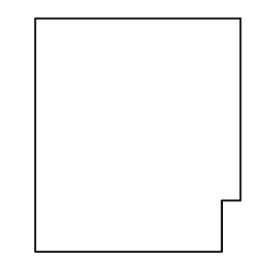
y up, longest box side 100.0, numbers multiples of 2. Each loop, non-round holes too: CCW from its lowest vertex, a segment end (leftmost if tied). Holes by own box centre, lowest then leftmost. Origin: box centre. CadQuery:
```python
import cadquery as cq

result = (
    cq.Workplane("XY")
    .moveTo(-44.0, -50.0)
    .lineTo(36.0, -50.0)
    .lineTo(36.0, -28.0)
    .lineTo(44.0, -28.0)
    .lineTo(44.0, 50.0)
    .lineTo(-44.0, 50.0)
    .close()
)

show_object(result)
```